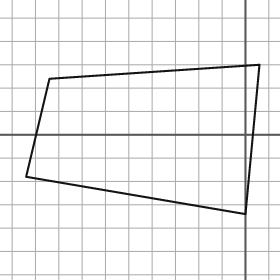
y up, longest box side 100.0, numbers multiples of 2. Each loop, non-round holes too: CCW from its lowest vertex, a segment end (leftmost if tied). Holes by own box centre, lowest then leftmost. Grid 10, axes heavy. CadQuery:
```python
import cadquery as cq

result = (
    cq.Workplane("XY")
    .moveTo(0.0, -34.0)
    .lineTo(6.0, 30.0)
    .lineTo(-84.0, 24.0)
    .lineTo(-94.0, -18.0)
    .close()
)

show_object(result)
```